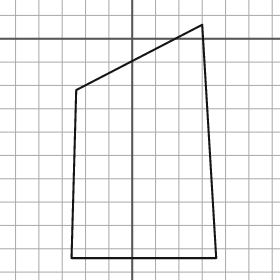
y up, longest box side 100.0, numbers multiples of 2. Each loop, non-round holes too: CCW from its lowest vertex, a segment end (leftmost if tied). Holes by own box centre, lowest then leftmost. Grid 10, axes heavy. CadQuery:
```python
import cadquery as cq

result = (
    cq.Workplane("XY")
    .moveTo(-26.0, -94.0)
    .lineTo(36.0, -94.0)
    .lineTo(30.0, 6.0)
    .lineTo(-24.0, -22.0)
    .close()
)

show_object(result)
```